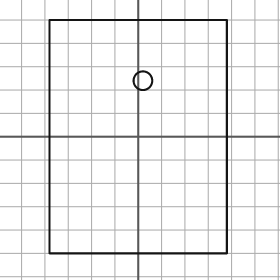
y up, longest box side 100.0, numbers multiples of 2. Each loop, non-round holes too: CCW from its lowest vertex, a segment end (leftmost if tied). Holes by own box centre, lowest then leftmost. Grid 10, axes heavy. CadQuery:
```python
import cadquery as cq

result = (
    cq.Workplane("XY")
    .moveTo(-38.0, -50.0)
    .lineTo(38.0, -50.0)
    .lineTo(38.0, 50.0)
    .lineTo(-38.0, 50.0)
    .close()
    .moveTo(2.0, 24.0)
    .circle(4.0)
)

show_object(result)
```